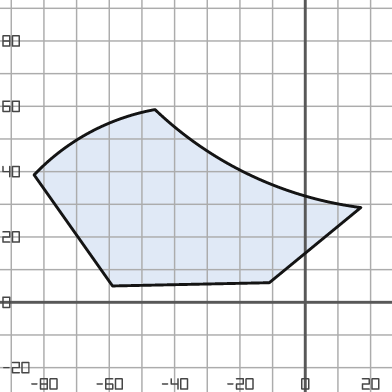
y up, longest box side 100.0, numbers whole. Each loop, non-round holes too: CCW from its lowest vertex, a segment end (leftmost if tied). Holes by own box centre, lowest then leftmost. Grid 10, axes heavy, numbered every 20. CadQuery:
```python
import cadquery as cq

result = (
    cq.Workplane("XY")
    .moveTo(-59.0, 5.0)
    .lineTo(-11.0, 6.0)
    .lineTo(17.0, 29.0)
    .threePointArc((-17.0, 39.0), (-46.0, 59.0))
    .threePointArc((-66.0, 52.0), (-83.0, 39.0))
    .close()
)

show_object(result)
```